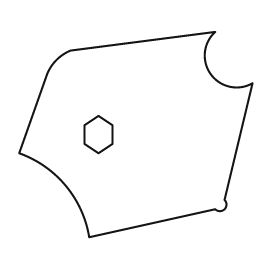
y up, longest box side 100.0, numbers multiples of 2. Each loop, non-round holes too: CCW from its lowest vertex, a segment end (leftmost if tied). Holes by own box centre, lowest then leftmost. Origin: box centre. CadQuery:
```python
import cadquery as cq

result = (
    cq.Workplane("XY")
    .moveTo(-20.0, -44.0)
    .lineTo(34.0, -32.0)
    .threePointArc((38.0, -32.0), (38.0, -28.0))
    .lineTo(50.0, 22.0)
    .threePointArc((32.0, 26.0), (34.0, 44.0))
    .lineTo(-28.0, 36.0)
    .threePointArc((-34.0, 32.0), (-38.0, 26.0))
    .lineTo(-50.0, -8.0)
    .threePointArc((-30.0, -22.0), (-20.0, -44.0))
    .close()
    .moveTo(-16.0, -8.0)
    .lineTo(-10.0, -4.0)
    .lineTo(-10.0, 4.0)
    .lineTo(-16.0, 8.0)
    .lineTo(-22.0, 4.0)
    .lineTo(-22.0, -4.0)
    .close()
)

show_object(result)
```